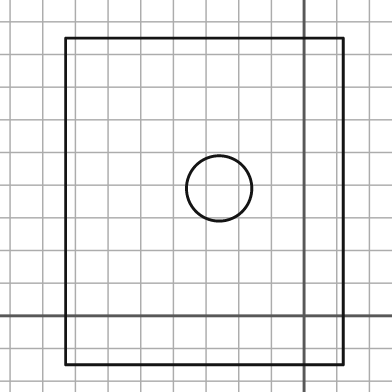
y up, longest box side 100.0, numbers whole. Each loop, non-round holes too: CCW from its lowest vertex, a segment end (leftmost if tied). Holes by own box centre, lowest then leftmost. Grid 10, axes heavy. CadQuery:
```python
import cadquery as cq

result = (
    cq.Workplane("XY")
    .moveTo(-73.0, -15.0)
    .lineTo(12.0, -15.0)
    .lineTo(12.0, 85.0)
    .lineTo(-73.0, 85.0)
    .close()
    .moveTo(-26.0, 39.0)
    .circle(10.0)
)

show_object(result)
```